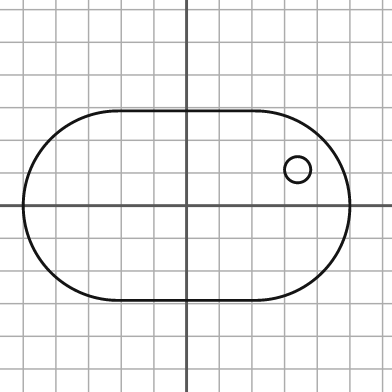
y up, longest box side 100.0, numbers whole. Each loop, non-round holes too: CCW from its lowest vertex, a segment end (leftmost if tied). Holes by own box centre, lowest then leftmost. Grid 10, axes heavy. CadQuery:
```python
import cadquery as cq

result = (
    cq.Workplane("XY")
    .moveTo(-21.0, -29.0)
    .lineTo(21.0, -29.0)
    .threePointArc((50.0, 0.0), (21.0, 29.0))
    .lineTo(-21.0, 29.0)
    .threePointArc((-50.0, 0.0), (-21.0, -29.0))
    .close()
    .moveTo(34.0, 11.0)
    .circle(4.0)
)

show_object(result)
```